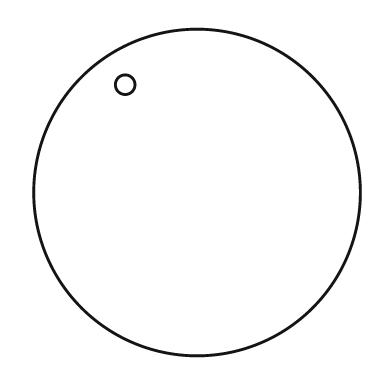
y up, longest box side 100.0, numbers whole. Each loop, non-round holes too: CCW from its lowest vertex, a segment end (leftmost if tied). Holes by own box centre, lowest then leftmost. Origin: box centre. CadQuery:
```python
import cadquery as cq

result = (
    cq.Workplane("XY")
    .moveTo(0.0, 0.0)
    .circle(50.0)
    .moveTo(-22.0, 33.0)
    .circle(3.0)
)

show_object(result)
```